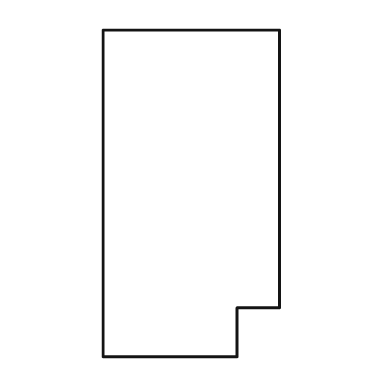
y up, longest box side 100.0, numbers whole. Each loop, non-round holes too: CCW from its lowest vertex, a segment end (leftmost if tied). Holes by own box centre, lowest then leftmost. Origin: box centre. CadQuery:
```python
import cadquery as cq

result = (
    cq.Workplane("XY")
    .moveTo(-27.0, -50.0)
    .lineTo(14.0, -50.0)
    .lineTo(14.0, -35.0)
    .lineTo(27.0, -35.0)
    .lineTo(27.0, 50.0)
    .lineTo(-27.0, 50.0)
    .close()
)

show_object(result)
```